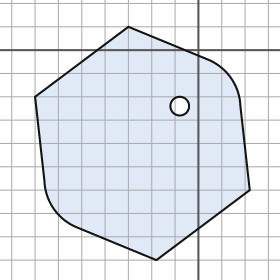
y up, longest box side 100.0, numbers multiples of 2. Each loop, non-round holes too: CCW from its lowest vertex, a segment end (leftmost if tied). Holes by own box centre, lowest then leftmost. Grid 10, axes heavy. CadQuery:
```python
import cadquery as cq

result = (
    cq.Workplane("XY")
    .moveTo(-18.0, -90.0)
    .lineTo(22.0, -60.0)
    .lineTo(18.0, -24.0)
    .threePointArc((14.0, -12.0), (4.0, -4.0))
    .lineTo(-30.0, 10.0)
    .lineTo(-70.0, -20.0)
    .lineTo(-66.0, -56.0)
    .threePointArc((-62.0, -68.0), (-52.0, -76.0))
    .close()
    .moveTo(-8.0, -24.0)
    .circle(4.0)
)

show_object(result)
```